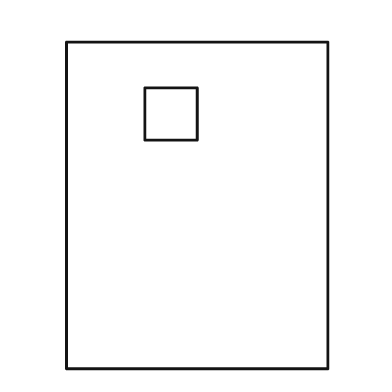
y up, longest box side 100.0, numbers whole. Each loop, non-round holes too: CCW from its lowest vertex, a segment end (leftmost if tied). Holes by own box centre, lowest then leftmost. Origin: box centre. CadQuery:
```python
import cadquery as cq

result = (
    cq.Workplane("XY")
    .moveTo(-40.0, -50.0)
    .lineTo(40.0, -50.0)
    .lineTo(40.0, 50.0)
    .lineTo(-40.0, 50.0)
    .close()
    .moveTo(-16.0, 20.0)
    .lineTo(0.0, 20.0)
    .lineTo(0.0, 36.0)
    .lineTo(-16.0, 36.0)
    .close()
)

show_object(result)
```